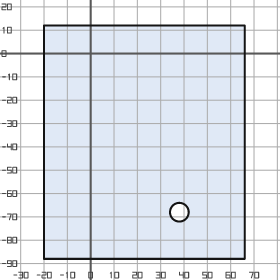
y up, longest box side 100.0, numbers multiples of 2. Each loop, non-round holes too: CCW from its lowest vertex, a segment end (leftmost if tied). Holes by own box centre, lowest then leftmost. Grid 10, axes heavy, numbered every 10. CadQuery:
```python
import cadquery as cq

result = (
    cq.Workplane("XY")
    .moveTo(-20.0, -88.0)
    .lineTo(66.0, -88.0)
    .lineTo(66.0, 12.0)
    .lineTo(-20.0, 12.0)
    .close()
    .moveTo(38.0, -68.0)
    .circle(4.0)
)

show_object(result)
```